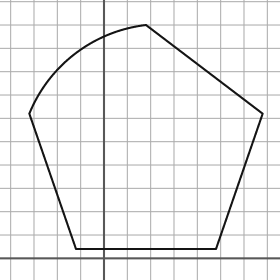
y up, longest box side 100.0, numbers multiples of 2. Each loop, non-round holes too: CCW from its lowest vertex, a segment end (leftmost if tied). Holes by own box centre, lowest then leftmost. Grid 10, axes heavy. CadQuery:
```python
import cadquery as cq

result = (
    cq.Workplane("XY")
    .moveTo(-12.0, 4.0)
    .lineTo(48.0, 4.0)
    .lineTo(68.0, 62.0)
    .lineTo(18.0, 100.0)
    .threePointArc((-12.0, 88.0), (-32.0, 62.0))
    .close()
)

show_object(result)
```